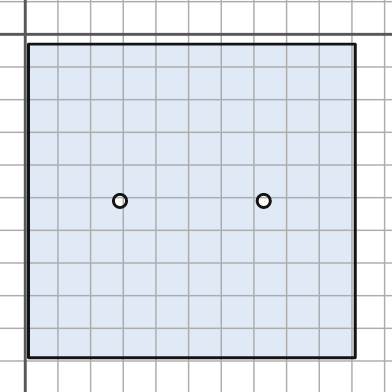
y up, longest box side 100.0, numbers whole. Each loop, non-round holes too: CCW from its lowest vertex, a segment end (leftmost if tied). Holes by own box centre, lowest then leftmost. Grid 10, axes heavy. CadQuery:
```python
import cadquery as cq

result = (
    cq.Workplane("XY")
    .moveTo(1.0, -99.0)
    .lineTo(101.0, -99.0)
    .lineTo(101.0, -3.0)
    .lineTo(1.0, -3.0)
    .close()
    .moveTo(29.0, -51.0)
    .circle(2.0)
    .moveTo(73.0, -51.0)
    .circle(2.0)
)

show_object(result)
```